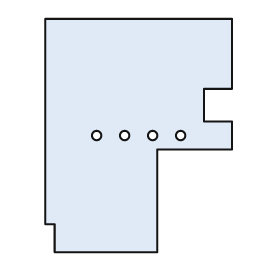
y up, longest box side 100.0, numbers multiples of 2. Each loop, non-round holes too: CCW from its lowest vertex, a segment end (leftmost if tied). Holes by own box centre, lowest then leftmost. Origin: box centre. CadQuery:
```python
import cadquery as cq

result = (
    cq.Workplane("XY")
    .moveTo(-36.0, -50.0)
    .lineTo(8.0, -50.0)
    .lineTo(8.0, -6.0)
    .lineTo(40.0, -6.0)
    .lineTo(40.0, 6.0)
    .lineTo(28.0, 6.0)
    .lineTo(28.0, 20.0)
    .lineTo(40.0, 20.0)
    .lineTo(40.0, 50.0)
    .lineTo(-40.0, 50.0)
    .lineTo(-40.0, -38.0)
    .lineTo(-36.0, -38.0)
    .close()
    .moveTo(-18.0, 0.0)
    .circle(2.0)
    .moveTo(-6.0, 0.0)
    .circle(2.0)
    .moveTo(6.0, 0.0)
    .circle(2.0)
    .moveTo(18.0, 0.0)
    .circle(2.0)
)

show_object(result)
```